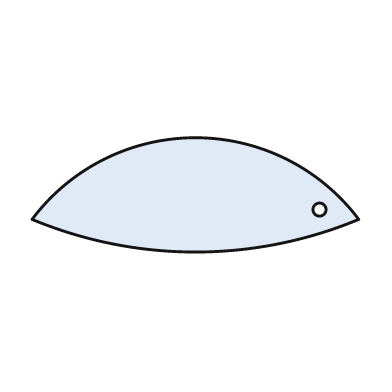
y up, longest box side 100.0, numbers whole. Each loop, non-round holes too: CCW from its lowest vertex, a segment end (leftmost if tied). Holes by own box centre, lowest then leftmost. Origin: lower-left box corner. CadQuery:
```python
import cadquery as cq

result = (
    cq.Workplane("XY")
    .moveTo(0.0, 10.0)
    .threePointArc((50.0, 0.0), (100.0, 10.0))
    .threePointArc((50.0, 35.0), (0.0, 10.0))
    .close()
    .moveTo(88.0, 13.0)
    .circle(2.0)
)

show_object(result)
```